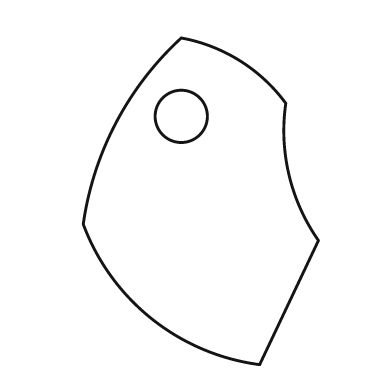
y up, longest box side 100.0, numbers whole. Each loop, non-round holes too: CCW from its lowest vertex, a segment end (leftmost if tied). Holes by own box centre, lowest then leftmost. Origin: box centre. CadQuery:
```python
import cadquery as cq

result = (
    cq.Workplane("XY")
    .moveTo(18.0, -50.0)
    .lineTo(36.0, -12.0)
    .threePointArc((27.0, 8.0), (26.0, 30.0))
    .threePointArc((12.0, 43.0), (-6.0, 50.0))
    .threePointArc((-26.0, 24.0), (-36.0, -7.0))
    .threePointArc((-15.0, -36.0), (18.0, -50.0))
    .close()
    .moveTo(-6.0, 26.0)
    .circle(8.0)
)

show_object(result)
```